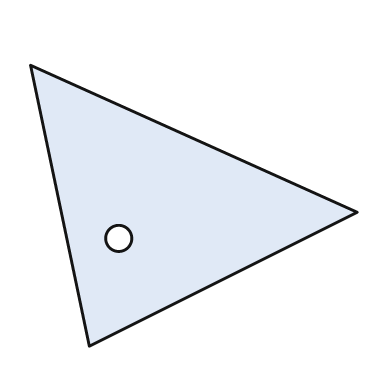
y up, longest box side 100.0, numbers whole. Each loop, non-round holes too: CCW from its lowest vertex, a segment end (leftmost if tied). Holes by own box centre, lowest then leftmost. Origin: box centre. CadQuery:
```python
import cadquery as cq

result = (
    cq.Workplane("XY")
    .moveTo(-32.0, -43.0)
    .lineTo(50.0, -2.0)
    .lineTo(-50.0, 43.0)
    .close()
    .moveTo(-23.0, -10.0)
    .circle(4.0)
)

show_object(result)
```